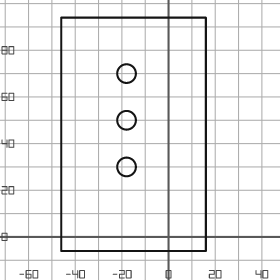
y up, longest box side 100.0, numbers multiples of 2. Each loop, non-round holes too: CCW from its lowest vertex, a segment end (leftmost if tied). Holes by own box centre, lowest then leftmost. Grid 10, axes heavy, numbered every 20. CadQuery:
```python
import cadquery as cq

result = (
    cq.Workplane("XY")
    .moveTo(-46.0, -6.0)
    .lineTo(16.0, -6.0)
    .lineTo(16.0, 94.0)
    .lineTo(-46.0, 94.0)
    .close()
    .moveTo(-18.0, 30.0)
    .circle(4.0)
    .moveTo(-18.0, 50.0)
    .circle(4.0)
    .moveTo(-18.0, 70.0)
    .circle(4.0)
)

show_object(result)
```